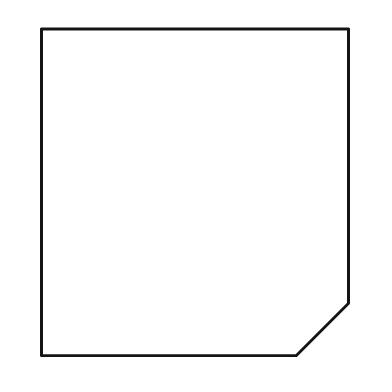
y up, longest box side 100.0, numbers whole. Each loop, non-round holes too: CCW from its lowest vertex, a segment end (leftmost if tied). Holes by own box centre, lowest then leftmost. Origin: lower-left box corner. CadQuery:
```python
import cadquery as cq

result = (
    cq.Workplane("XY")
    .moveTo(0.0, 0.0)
    .lineTo(78.0, 0.0)
    .lineTo(94.0, 16.0)
    .lineTo(94.0, 100.0)
    .lineTo(0.0, 100.0)
    .close()
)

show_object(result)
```